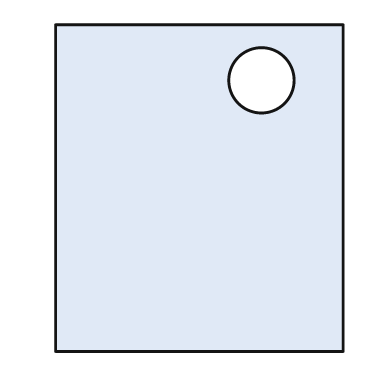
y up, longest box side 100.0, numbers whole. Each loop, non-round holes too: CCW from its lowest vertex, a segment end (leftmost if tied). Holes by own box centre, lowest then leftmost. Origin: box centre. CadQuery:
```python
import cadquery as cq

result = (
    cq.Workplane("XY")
    .moveTo(-44.0, -50.0)
    .lineTo(44.0, -50.0)
    .lineTo(44.0, 50.0)
    .lineTo(-44.0, 50.0)
    .close()
    .moveTo(19.0, 33.0)
    .circle(10.0)
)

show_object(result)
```